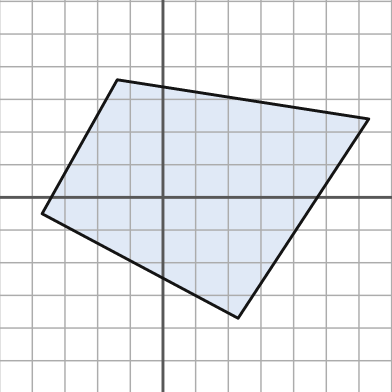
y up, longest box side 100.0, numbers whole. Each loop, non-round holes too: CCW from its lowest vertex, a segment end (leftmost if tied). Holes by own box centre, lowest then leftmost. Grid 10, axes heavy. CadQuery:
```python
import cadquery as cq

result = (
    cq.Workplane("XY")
    .moveTo(23.0, -37.0)
    .lineTo(63.0, 24.0)
    .lineTo(-14.0, 36.0)
    .lineTo(-37.0, -5.0)
    .close()
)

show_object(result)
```